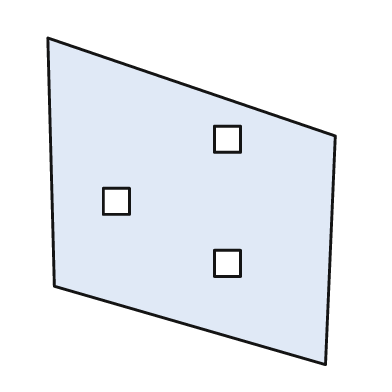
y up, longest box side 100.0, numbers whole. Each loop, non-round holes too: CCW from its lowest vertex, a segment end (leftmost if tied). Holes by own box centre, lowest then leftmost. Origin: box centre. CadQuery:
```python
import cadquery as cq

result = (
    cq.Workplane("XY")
    .moveTo(41.0, -50.0)
    .lineTo(44.0, 20.0)
    .lineTo(-44.0, 50.0)
    .lineTo(-42.0, -26.0)
    .close()
    .moveTo(7.0, -23.0)
    .lineTo(15.0, -23.0)
    .lineTo(15.0, -15.0)
    .lineTo(7.0, -15.0)
    .close()
    .moveTo(-27.0, -4.0)
    .lineTo(-19.0, -4.0)
    .lineTo(-19.0, 4.0)
    .lineTo(-27.0, 4.0)
    .close()
    .moveTo(7.0, 15.0)
    .lineTo(15.0, 15.0)
    .lineTo(15.0, 23.0)
    .lineTo(7.0, 23.0)
    .close()
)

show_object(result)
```